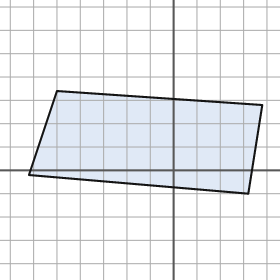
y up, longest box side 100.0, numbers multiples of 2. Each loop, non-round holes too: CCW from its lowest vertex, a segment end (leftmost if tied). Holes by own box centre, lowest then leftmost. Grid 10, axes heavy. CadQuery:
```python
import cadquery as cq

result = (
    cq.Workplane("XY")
    .moveTo(32.0, -10.0)
    .lineTo(38.0, 28.0)
    .lineTo(-50.0, 34.0)
    .lineTo(-62.0, -2.0)
    .close()
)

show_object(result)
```